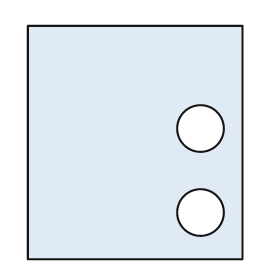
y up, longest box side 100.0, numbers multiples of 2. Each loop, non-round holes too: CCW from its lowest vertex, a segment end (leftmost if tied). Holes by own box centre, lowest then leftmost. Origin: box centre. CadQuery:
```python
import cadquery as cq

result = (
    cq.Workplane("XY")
    .moveTo(-46.0, -50.0)
    .lineTo(46.0, -50.0)
    .lineTo(46.0, 50.0)
    .lineTo(-46.0, 50.0)
    .close()
    .moveTo(28.0, -30.0)
    .circle(10.0)
    .moveTo(28.0, 6.0)
    .circle(10.0)
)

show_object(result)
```